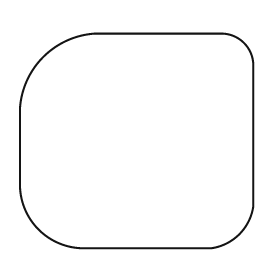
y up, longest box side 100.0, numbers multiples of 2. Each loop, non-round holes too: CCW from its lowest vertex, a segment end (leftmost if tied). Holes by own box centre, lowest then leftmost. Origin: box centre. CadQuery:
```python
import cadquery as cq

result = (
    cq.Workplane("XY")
    .moveTo(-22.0, -46.0)
    .lineTo(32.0, -46.0)
    .threePointArc((44.0, -40.0), (50.0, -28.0))
    .lineTo(50.0, 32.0)
    .threePointArc((46.0, 42.0), (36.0, 46.0))
    .lineTo(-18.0, 46.0)
    .threePointArc((-40.0, 36.0), (-50.0, 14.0))
    .lineTo(-50.0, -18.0)
    .threePointArc((-42.0, -38.0), (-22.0, -46.0))
    .close()
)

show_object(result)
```